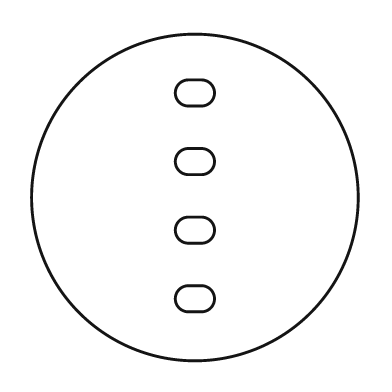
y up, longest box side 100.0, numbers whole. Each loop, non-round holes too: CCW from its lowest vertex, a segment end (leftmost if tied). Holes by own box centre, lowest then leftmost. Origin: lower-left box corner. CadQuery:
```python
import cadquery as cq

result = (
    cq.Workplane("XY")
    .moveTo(50.0, 50.0)
    .circle(50.0)
    .moveTo(48.0, 15.0)
    .lineTo(52.0, 15.0)
    .threePointArc((56.0, 19.0), (52.0, 23.0))
    .lineTo(48.0, 23.0)
    .threePointArc((44.0, 19.0), (48.0, 15.0))
    .close()
    .moveTo(48.0, 36.0)
    .lineTo(52.0, 36.0)
    .threePointArc((56.0, 40.0), (52.0, 44.0))
    .lineTo(48.0, 44.0)
    .threePointArc((44.0, 40.0), (48.0, 36.0))
    .close()
    .moveTo(48.0, 57.0)
    .lineTo(52.0, 57.0)
    .threePointArc((56.0, 61.0), (52.0, 65.0))
    .lineTo(48.0, 65.0)
    .threePointArc((44.0, 61.0), (48.0, 57.0))
    .close()
    .moveTo(48.0, 78.0)
    .lineTo(52.0, 78.0)
    .threePointArc((56.0, 82.0), (52.0, 86.0))
    .lineTo(48.0, 86.0)
    .threePointArc((44.0, 82.0), (48.0, 78.0))
    .close()
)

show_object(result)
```